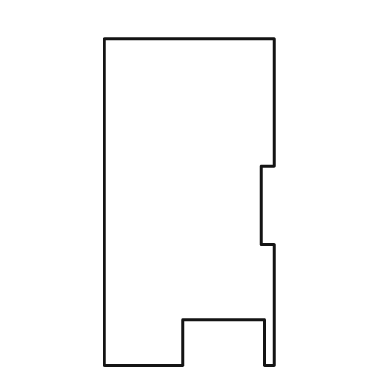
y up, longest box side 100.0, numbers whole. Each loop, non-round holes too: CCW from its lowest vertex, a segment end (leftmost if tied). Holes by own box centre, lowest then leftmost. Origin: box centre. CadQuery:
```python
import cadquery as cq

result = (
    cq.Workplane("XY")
    .moveTo(-26.0, -50.0)
    .lineTo(-2.0, -50.0)
    .lineTo(-2.0, -36.0)
    .lineTo(23.0, -36.0)
    .lineTo(23.0, -50.0)
    .lineTo(26.0, -50.0)
    .lineTo(26.0, -13.0)
    .lineTo(22.0, -13.0)
    .lineTo(22.0, 11.0)
    .lineTo(26.0, 11.0)
    .lineTo(26.0, 50.0)
    .lineTo(-26.0, 50.0)
    .close()
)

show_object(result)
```